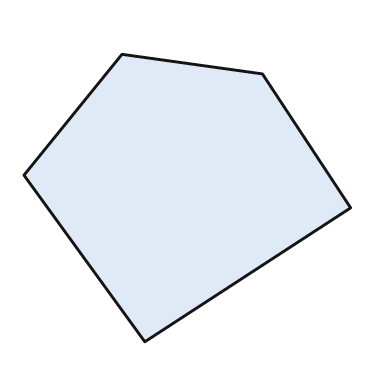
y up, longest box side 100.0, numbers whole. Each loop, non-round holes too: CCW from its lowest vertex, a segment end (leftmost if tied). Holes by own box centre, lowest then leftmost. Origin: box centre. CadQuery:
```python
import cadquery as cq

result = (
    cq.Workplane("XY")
    .moveTo(-13.0, -44.0)
    .lineTo(50.0, -3.0)
    .lineTo(23.0, 38.0)
    .lineTo(-20.0, 44.0)
    .lineTo(-50.0, 7.0)
    .close()
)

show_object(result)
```